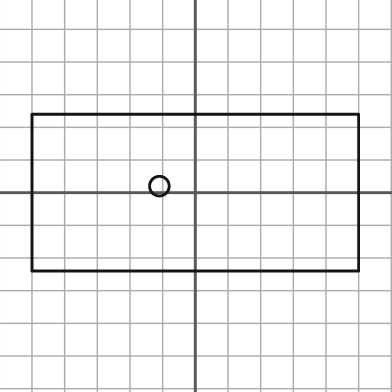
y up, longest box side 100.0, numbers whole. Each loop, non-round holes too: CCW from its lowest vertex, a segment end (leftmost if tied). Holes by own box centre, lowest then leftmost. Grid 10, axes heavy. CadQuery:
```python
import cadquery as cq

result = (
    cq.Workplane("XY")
    .moveTo(-50.0, -24.0)
    .lineTo(50.0, -24.0)
    .lineTo(50.0, 24.0)
    .lineTo(-50.0, 24.0)
    .close()
    .moveTo(-11.0, 2.0)
    .circle(3.0)
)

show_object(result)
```